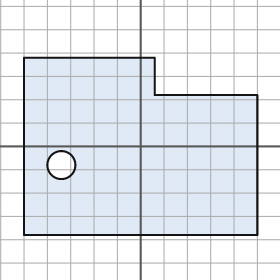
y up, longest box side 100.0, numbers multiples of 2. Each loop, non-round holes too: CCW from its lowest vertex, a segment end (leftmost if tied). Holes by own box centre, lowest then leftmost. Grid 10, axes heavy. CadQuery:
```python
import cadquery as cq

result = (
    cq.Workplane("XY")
    .moveTo(-50.0, -38.0)
    .lineTo(50.0, -38.0)
    .lineTo(50.0, 22.0)
    .lineTo(6.0, 22.0)
    .lineTo(6.0, 38.0)
    .lineTo(-50.0, 38.0)
    .close()
    .moveTo(-34.0, -8.0)
    .circle(6.0)
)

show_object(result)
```